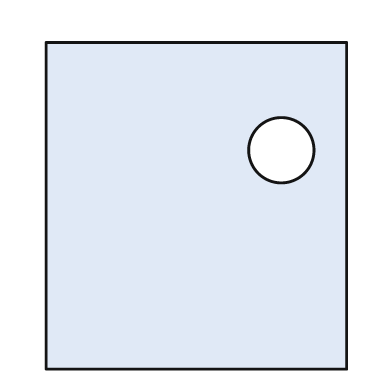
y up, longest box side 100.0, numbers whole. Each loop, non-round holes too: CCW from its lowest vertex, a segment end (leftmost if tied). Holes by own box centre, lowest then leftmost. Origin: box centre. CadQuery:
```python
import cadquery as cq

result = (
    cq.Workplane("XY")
    .moveTo(-46.0, -50.0)
    .lineTo(46.0, -50.0)
    .lineTo(46.0, 50.0)
    .lineTo(-46.0, 50.0)
    .close()
    .moveTo(26.0, 17.0)
    .circle(10.0)
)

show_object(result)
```